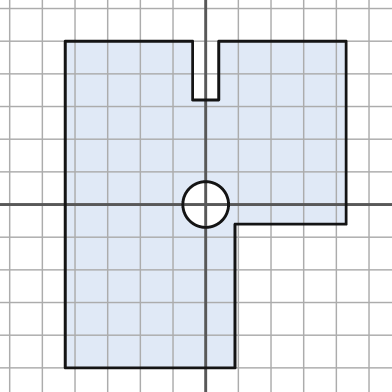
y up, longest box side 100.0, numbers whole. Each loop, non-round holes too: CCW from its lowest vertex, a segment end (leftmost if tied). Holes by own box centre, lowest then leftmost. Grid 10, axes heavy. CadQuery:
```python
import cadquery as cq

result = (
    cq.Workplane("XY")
    .moveTo(-43.0, -50.0)
    .lineTo(9.0, -50.0)
    .lineTo(9.0, -6.0)
    .lineTo(43.0, -6.0)
    .lineTo(43.0, 50.0)
    .lineTo(4.0, 50.0)
    .lineTo(4.0, 32.0)
    .lineTo(-4.0, 32.0)
    .lineTo(-4.0, 50.0)
    .lineTo(-43.0, 50.0)
    .close()
    .moveTo(0.0, 0.0)
    .circle(7.0)
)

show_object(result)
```